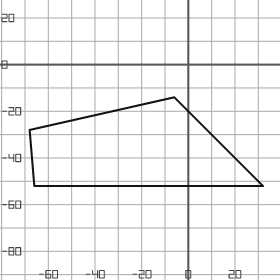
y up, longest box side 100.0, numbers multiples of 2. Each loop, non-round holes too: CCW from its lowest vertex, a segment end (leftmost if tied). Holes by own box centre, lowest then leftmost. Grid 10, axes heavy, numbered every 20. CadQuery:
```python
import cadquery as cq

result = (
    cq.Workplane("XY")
    .moveTo(-66.0, -52.0)
    .lineTo(32.0, -52.0)
    .lineTo(-6.0, -14.0)
    .lineTo(-68.0, -28.0)
    .close()
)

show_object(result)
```